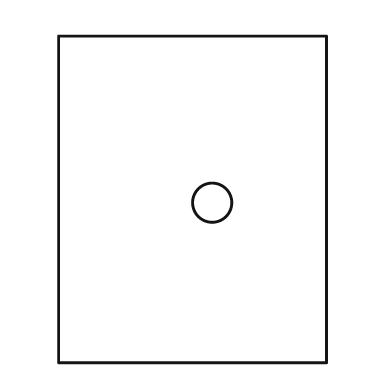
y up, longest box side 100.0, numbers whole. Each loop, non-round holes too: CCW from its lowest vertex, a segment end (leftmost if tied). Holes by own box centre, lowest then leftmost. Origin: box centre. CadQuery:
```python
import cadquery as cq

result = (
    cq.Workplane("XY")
    .moveTo(-41.0, -50.0)
    .lineTo(41.0, -50.0)
    .lineTo(41.0, 50.0)
    .lineTo(-41.0, 50.0)
    .close()
    .moveTo(6.0, -1.0)
    .circle(6.0)
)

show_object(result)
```